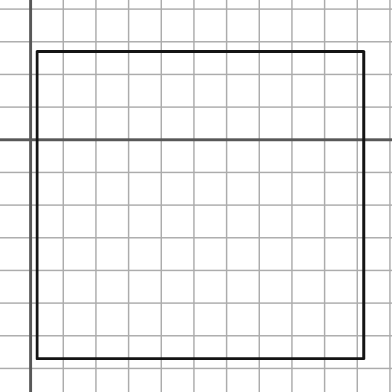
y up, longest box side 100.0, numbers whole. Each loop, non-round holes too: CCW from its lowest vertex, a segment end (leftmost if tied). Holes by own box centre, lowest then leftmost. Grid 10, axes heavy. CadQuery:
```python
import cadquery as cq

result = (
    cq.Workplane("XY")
    .moveTo(2.0, -67.0)
    .lineTo(102.0, -67.0)
    .lineTo(102.0, 27.0)
    .lineTo(2.0, 27.0)
    .close()
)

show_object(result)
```